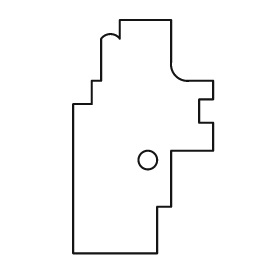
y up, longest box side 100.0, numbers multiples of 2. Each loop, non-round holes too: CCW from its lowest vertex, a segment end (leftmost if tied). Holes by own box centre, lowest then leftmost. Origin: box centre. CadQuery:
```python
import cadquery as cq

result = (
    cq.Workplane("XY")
    .moveTo(-30.0, -50.0)
    .lineTo(6.0, -50.0)
    .lineTo(6.0, -30.0)
    .lineTo(12.0, -30.0)
    .lineTo(12.0, -6.0)
    .lineTo(30.0, -6.0)
    .lineTo(30.0, 6.0)
    .lineTo(24.0, 6.0)
    .lineTo(24.0, 16.0)
    .lineTo(30.0, 16.0)
    .lineTo(30.0, 24.0)
    .lineTo(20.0, 24.0)
    .threePointArc((14.0, 26.0), (12.0, 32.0))
    .lineTo(12.0, 50.0)
    .lineTo(-10.0, 50.0)
    .lineTo(-10.0, 42.0)
    .threePointArc((-14.0, 44.0), (-18.0, 42.0))
    .lineTo(-18.0, 24.0)
    .lineTo(-22.0, 24.0)
    .lineTo(-22.0, 14.0)
    .lineTo(-30.0, 14.0)
    .close()
    .moveTo(2.0, -10.0)
    .circle(4.0)
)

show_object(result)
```